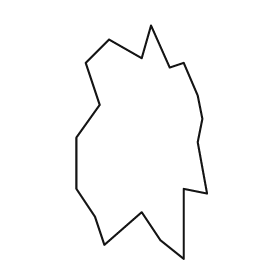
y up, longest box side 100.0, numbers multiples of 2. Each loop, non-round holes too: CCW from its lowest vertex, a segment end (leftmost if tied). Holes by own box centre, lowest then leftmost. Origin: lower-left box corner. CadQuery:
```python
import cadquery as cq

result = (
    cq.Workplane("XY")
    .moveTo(46.0, 0.0)
    .lineTo(46.0, 30.0)
    .lineTo(56.0, 28.0)
    .lineTo(52.0, 50.0)
    .lineTo(54.0, 60.0)
    .lineTo(52.0, 70.0)
    .lineTo(46.0, 84.0)
    .lineTo(40.0, 82.0)
    .lineTo(32.0, 100.0)
    .lineTo(28.0, 86.0)
    .lineTo(14.0, 94.0)
    .lineTo(4.0, 84.0)
    .lineTo(10.0, 66.0)
    .lineTo(0.0, 52.0)
    .lineTo(0.0, 30.0)
    .lineTo(8.0, 18.0)
    .lineTo(12.0, 6.0)
    .lineTo(28.0, 20.0)
    .lineTo(36.0, 8.0)
    .close()
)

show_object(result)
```